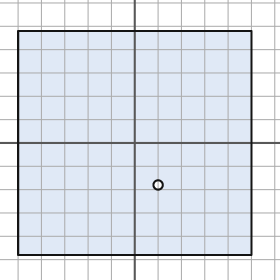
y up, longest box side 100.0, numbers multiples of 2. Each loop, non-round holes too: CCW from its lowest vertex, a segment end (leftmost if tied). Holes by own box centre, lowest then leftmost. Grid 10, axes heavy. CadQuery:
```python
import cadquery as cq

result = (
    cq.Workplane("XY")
    .moveTo(-50.0, -48.0)
    .lineTo(50.0, -48.0)
    .lineTo(50.0, 48.0)
    .lineTo(-50.0, 48.0)
    .close()
    .moveTo(10.0, -18.0)
    .circle(2.0)
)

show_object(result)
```